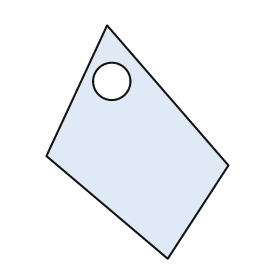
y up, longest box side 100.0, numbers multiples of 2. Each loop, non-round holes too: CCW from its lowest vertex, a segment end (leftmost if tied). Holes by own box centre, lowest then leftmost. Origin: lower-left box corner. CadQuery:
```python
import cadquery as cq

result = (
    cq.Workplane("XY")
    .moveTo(52.0, 0.0)
    .lineTo(78.0, 40.0)
    .lineTo(26.0, 100.0)
    .lineTo(0.0, 44.0)
    .close()
    .moveTo(28.0, 76.0)
    .circle(8.0)
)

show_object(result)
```